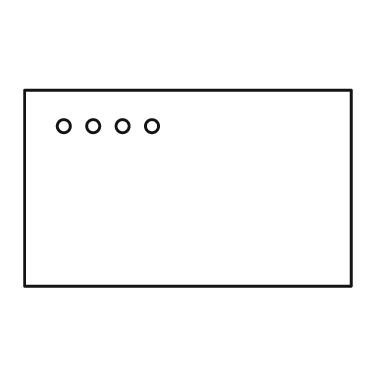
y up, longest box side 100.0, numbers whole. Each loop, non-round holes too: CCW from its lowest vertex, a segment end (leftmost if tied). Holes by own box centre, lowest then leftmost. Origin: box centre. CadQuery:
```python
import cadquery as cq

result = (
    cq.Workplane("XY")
    .moveTo(-50.0, -30.0)
    .lineTo(50.0, -30.0)
    .lineTo(50.0, 30.0)
    .lineTo(-50.0, 30.0)
    .close()
    .moveTo(-38.0, 19.0)
    .circle(2.0)
    .moveTo(-29.0, 19.0)
    .circle(2.0)
    .moveTo(-20.0, 19.0)
    .circle(2.0)
    .moveTo(-11.0, 19.0)
    .circle(2.0)
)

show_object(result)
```